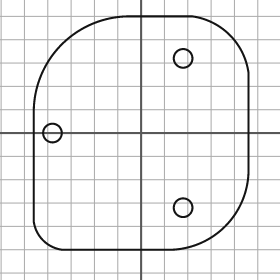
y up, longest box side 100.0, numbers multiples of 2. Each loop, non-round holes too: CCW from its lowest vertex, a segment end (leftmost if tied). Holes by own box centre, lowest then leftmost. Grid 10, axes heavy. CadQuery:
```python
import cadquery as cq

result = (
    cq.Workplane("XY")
    .moveTo(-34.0, -50.0)
    .lineTo(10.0, -50.0)
    .threePointArc((36.0, -40.0), (46.0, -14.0))
    .lineTo(46.0, 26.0)
    .threePointArc((38.0, 42.0), (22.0, 50.0))
    .lineTo(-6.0, 50.0)
    .threePointArc((-34.0, 38.0), (-46.0, 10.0))
    .lineTo(-46.0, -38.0)
    .threePointArc((-42.0, -46.0), (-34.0, -50.0))
    .close()
    .moveTo(18.0, -32.0)
    .circle(4.0)
    .moveTo(-38.0, 0.0)
    .circle(4.0)
    .moveTo(18.0, 32.0)
    .circle(4.0)
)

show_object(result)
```